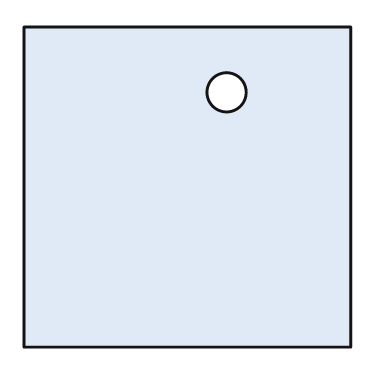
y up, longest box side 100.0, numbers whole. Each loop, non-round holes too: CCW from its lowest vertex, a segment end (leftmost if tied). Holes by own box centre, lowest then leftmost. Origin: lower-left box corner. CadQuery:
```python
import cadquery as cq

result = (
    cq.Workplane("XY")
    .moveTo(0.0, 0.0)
    .lineTo(100.0, 0.0)
    .lineTo(100.0, 98.0)
    .lineTo(0.0, 98.0)
    .close()
    .moveTo(62.0, 78.0)
    .circle(6.0)
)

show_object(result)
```